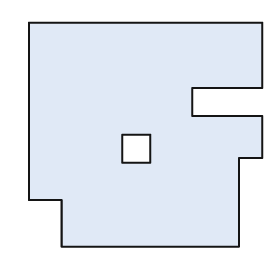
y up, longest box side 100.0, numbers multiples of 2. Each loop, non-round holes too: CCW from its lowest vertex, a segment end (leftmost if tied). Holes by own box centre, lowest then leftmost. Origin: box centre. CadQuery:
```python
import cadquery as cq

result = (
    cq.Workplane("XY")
    .moveTo(-36.0, -48.0)
    .lineTo(40.0, -48.0)
    .lineTo(40.0, -10.0)
    .lineTo(50.0, -10.0)
    .lineTo(50.0, 8.0)
    .lineTo(20.0, 8.0)
    .lineTo(20.0, 20.0)
    .lineTo(50.0, 20.0)
    .lineTo(50.0, 48.0)
    .lineTo(-50.0, 48.0)
    .lineTo(-50.0, -28.0)
    .lineTo(-36.0, -28.0)
    .close()
    .moveTo(-10.0, -12.0)
    .lineTo(2.0, -12.0)
    .lineTo(2.0, 0.0)
    .lineTo(-10.0, 0.0)
    .close()
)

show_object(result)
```